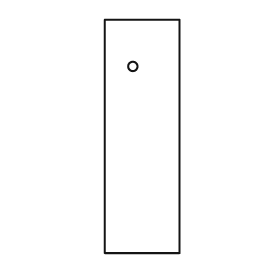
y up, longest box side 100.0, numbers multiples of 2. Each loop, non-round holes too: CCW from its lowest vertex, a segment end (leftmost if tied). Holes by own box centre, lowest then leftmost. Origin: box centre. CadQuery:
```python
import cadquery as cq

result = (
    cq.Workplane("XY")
    .moveTo(-16.0, -50.0)
    .lineTo(16.0, -50.0)
    .lineTo(16.0, 50.0)
    .lineTo(-16.0, 50.0)
    .close()
    .moveTo(-4.0, 30.0)
    .circle(2.0)
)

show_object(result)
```